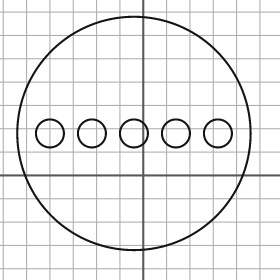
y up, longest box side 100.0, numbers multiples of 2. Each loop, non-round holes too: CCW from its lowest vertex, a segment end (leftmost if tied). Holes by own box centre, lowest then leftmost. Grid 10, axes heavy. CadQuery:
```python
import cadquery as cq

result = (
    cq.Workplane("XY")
    .moveTo(-4.0, 18.0)
    .circle(50.0)
    .moveTo(-40.0, 18.0)
    .circle(6.0)
    .moveTo(-22.0, 18.0)
    .circle(6.0)
    .moveTo(-4.0, 18.0)
    .circle(6.0)
    .moveTo(14.0, 18.0)
    .circle(6.0)
    .moveTo(32.0, 18.0)
    .circle(6.0)
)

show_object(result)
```